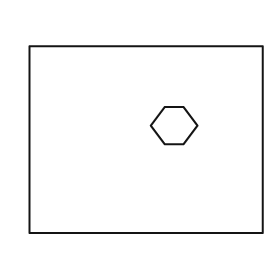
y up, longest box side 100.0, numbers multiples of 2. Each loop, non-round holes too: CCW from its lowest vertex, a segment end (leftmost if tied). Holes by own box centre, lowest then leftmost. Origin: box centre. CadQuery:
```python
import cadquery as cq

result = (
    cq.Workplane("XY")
    .moveTo(-50.0, -40.0)
    .lineTo(50.0, -40.0)
    .lineTo(50.0, 40.0)
    .lineTo(-50.0, 40.0)
    .close()
    .moveTo(8.0, -2.0)
    .lineTo(16.0, -2.0)
    .lineTo(22.0, 6.0)
    .lineTo(16.0, 14.0)
    .lineTo(8.0, 14.0)
    .lineTo(2.0, 6.0)
    .close()
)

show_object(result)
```